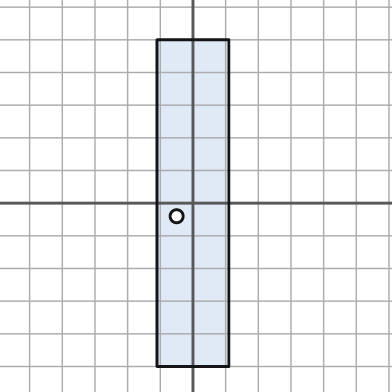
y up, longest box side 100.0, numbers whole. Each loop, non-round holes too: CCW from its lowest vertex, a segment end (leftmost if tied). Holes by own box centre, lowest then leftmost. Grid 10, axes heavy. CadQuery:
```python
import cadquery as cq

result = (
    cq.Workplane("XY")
    .moveTo(-11.0, -50.0)
    .lineTo(11.0, -50.0)
    .lineTo(11.0, 50.0)
    .lineTo(-11.0, 50.0)
    .close()
    .moveTo(-5.0, -4.0)
    .circle(2.0)
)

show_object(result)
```